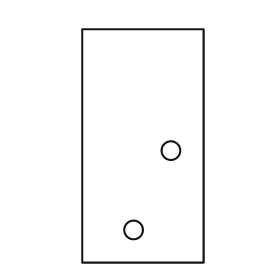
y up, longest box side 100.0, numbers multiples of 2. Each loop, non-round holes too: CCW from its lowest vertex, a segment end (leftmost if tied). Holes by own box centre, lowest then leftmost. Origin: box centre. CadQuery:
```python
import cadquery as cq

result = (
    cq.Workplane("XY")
    .moveTo(-26.0, -50.0)
    .lineTo(26.0, -50.0)
    .lineTo(26.0, 50.0)
    .lineTo(-26.0, 50.0)
    .close()
    .moveTo(-4.0, -36.0)
    .circle(4.0)
    .moveTo(12.0, -2.0)
    .circle(4.0)
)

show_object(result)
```